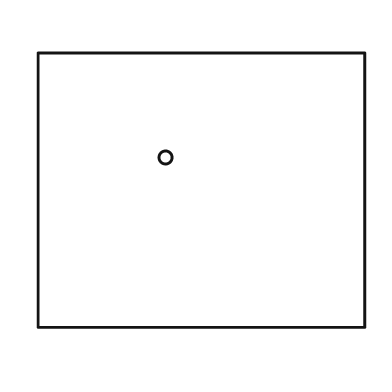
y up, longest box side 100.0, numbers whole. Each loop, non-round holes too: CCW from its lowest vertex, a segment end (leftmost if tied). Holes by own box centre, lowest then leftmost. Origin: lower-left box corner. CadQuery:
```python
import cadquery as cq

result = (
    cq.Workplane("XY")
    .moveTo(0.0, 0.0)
    .lineTo(100.0, 0.0)
    .lineTo(100.0, 84.0)
    .lineTo(0.0, 84.0)
    .close()
    .moveTo(39.0, 52.0)
    .circle(2.0)
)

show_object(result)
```